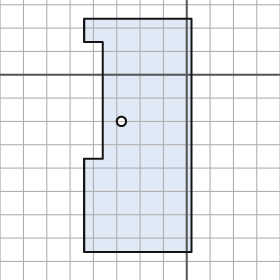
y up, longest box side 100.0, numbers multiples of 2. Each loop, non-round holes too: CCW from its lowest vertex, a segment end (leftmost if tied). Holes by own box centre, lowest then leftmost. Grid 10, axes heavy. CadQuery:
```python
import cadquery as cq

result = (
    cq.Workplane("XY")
    .moveTo(-44.0, -76.0)
    .lineTo(2.0, -76.0)
    .lineTo(2.0, 24.0)
    .lineTo(-44.0, 24.0)
    .lineTo(-44.0, 14.0)
    .lineTo(-36.0, 14.0)
    .lineTo(-36.0, -36.0)
    .lineTo(-44.0, -36.0)
    .close()
    .moveTo(-28.0, -20.0)
    .circle(2.0)
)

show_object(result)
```